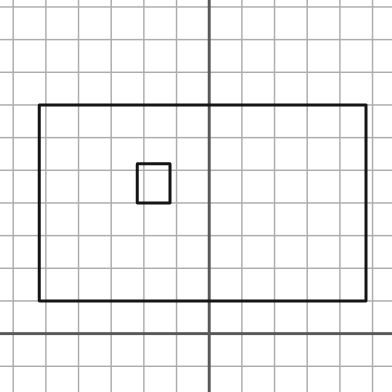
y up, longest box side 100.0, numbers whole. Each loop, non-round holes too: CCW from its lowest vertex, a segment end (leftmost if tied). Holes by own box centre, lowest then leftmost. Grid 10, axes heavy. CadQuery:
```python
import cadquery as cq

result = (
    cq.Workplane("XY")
    .moveTo(-52.0, 10.0)
    .lineTo(48.0, 10.0)
    .lineTo(48.0, 70.0)
    .lineTo(-52.0, 70.0)
    .close()
    .moveTo(-22.0, 40.0)
    .lineTo(-12.0, 40.0)
    .lineTo(-12.0, 52.0)
    .lineTo(-22.0, 52.0)
    .close()
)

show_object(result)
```